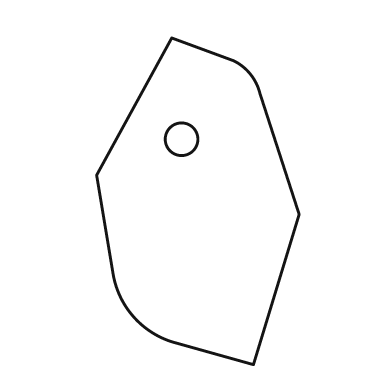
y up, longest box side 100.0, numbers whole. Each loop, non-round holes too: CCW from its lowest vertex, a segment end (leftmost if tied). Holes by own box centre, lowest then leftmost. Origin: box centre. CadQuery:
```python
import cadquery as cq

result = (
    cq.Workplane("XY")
    .moveTo(17.0, -50.0)
    .lineTo(31.0, -4.0)
    .lineTo(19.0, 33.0)
    .threePointArc((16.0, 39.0), (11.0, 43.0))
    .lineTo(-8.0, 50.0)
    .lineTo(-31.0, 8.0)
    .lineTo(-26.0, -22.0)
    .threePointArc((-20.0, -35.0), (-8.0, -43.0))
    .close()
    .moveTo(-5.0, 19.0)
    .circle(5.0)
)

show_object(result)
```